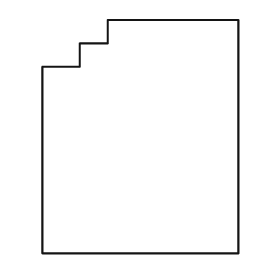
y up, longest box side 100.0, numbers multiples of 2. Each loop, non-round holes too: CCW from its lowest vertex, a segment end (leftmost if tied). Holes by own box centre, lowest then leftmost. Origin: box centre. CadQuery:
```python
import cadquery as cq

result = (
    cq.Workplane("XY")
    .moveTo(-42.0, -50.0)
    .lineTo(42.0, -50.0)
    .lineTo(42.0, 50.0)
    .lineTo(-14.0, 50.0)
    .lineTo(-14.0, 40.0)
    .lineTo(-26.0, 40.0)
    .lineTo(-26.0, 30.0)
    .lineTo(-42.0, 30.0)
    .close()
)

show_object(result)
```